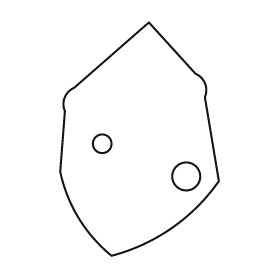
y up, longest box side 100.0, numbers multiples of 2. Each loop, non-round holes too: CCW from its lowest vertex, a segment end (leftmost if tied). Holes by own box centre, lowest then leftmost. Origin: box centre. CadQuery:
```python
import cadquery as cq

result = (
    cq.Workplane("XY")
    .moveTo(-12.0, -50.0)
    .threePointArc((14.0, -38.0), (34.0, -18.0))
    .lineTo(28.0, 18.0)
    .threePointArc((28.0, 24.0), (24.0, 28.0))
    .lineTo(4.0, 50.0)
    .lineTo(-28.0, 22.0)
    .threePointArc((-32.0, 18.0), (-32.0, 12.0))
    .lineTo(-34.0, -14.0)
    .threePointArc((-26.0, -34.0), (-12.0, -50.0))
    .close()
    .moveTo(20.0, -16.0)
    .circle(6.0)
    .moveTo(-16.0, -2.0)
    .circle(4.0)
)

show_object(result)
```